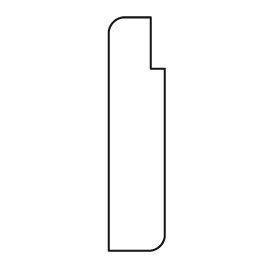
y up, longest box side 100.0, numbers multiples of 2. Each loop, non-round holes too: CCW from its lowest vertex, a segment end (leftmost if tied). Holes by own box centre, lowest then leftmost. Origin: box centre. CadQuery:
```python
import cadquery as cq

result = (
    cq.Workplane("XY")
    .moveTo(-12.0, -50.0)
    .lineTo(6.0, -50.0)
    .threePointArc((10.0, -48.0), (12.0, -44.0))
    .lineTo(12.0, 28.0)
    .lineTo(6.0, 28.0)
    .lineTo(6.0, 50.0)
    .lineTo(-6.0, 50.0)
    .threePointArc((-10.0, 48.0), (-12.0, 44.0))
    .close()
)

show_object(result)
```